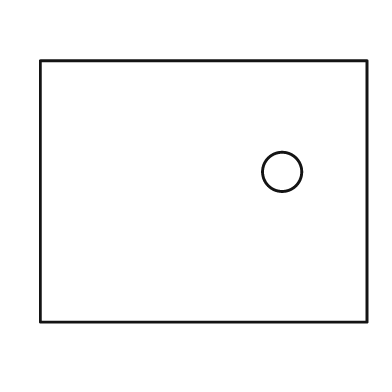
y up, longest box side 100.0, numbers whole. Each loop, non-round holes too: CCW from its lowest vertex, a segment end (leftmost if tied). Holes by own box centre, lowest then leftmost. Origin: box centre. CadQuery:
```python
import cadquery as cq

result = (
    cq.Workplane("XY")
    .moveTo(-50.0, -40.0)
    .lineTo(50.0, -40.0)
    .lineTo(50.0, 40.0)
    .lineTo(-50.0, 40.0)
    .close()
    .moveTo(24.0, 6.0)
    .circle(6.0)
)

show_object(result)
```